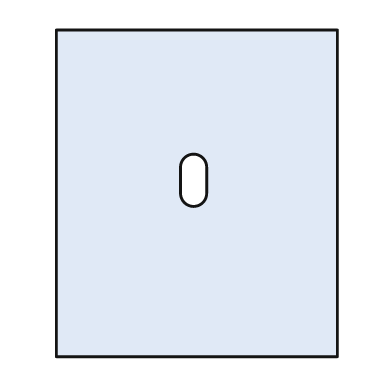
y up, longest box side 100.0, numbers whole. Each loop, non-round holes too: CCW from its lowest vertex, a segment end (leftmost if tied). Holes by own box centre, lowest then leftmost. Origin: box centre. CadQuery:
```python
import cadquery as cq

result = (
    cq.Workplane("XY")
    .moveTo(-43.0, -50.0)
    .lineTo(43.0, -50.0)
    .lineTo(43.0, 50.0)
    .lineTo(-43.0, 50.0)
    .close()
    .moveTo(-5.0, 0.0)
    .threePointArc((-1.0, -4.0), (3.0, 0.0))
    .lineTo(3.0, 8.0)
    .threePointArc((-1.0, 12.0), (-5.0, 8.0))
    .close()
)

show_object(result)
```